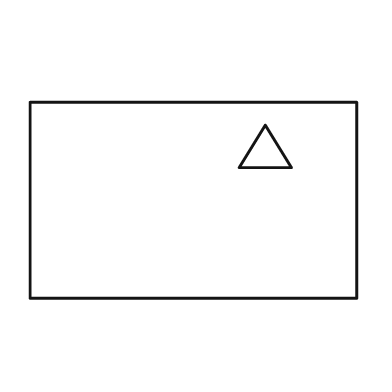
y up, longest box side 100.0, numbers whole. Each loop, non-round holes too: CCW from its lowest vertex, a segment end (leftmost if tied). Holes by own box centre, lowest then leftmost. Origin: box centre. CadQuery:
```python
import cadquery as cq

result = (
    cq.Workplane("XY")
    .moveTo(-50.0, -30.0)
    .lineTo(50.0, -30.0)
    .lineTo(50.0, 30.0)
    .lineTo(-50.0, 30.0)
    .close()
    .moveTo(14.0, 10.0)
    .lineTo(30.0, 10.0)
    .lineTo(22.0, 23.0)
    .close()
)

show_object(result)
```